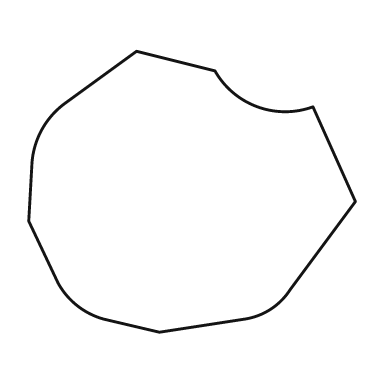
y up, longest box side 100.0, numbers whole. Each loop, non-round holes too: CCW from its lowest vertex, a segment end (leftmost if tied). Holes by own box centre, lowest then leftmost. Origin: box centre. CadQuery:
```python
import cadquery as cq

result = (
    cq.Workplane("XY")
    .moveTo(-10.0, -43.0)
    .lineTo(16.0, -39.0)
    .threePointArc((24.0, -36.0), (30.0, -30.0))
    .lineTo(50.0, -3.0)
    .lineTo(37.0, 26.0)
    .threePointArc((20.0, 26.0), (7.0, 37.0))
    .lineTo(-17.0, 43.0)
    .lineTo(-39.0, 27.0)
    .threePointArc((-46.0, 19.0), (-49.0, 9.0))
    .lineTo(-50.0, -9.0)
    .lineTo(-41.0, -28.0)
    .threePointArc((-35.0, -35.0), (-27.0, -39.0))
    .close()
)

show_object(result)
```